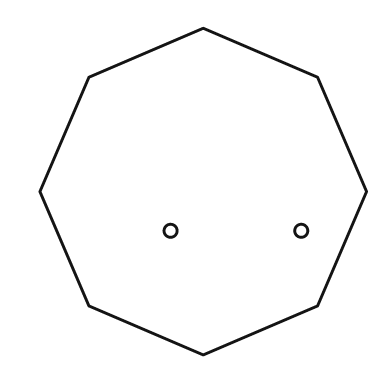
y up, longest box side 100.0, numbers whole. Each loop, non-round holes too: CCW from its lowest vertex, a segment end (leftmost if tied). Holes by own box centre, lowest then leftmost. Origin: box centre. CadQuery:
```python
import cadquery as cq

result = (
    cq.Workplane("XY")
    .moveTo(0.0, -50.0)
    .lineTo(35.0, -35.0)
    .lineTo(50.0, 0.0)
    .lineTo(35.0, 35.0)
    .lineTo(0.0, 50.0)
    .lineTo(-35.0, 35.0)
    .lineTo(-50.0, 0.0)
    .lineTo(-35.0, -35.0)
    .close()
    .moveTo(-10.0, -12.0)
    .circle(2.0)
    .moveTo(30.0, -12.0)
    .circle(2.0)
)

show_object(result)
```